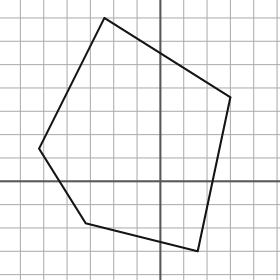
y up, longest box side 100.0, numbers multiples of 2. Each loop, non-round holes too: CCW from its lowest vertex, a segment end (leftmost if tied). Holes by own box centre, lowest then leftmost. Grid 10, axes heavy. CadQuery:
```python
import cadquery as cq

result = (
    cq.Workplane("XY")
    .moveTo(16.0, -30.0)
    .lineTo(30.0, 36.0)
    .lineTo(-24.0, 70.0)
    .lineTo(-52.0, 14.0)
    .lineTo(-32.0, -18.0)
    .close()
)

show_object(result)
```